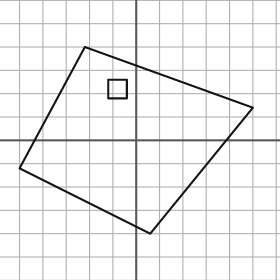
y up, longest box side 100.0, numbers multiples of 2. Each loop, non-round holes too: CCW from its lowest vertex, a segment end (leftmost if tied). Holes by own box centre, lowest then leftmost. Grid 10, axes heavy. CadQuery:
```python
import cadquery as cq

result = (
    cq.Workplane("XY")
    .moveTo(6.0, -40.0)
    .lineTo(50.0, 14.0)
    .lineTo(-22.0, 40.0)
    .lineTo(-50.0, -12.0)
    .close()
    .moveTo(-12.0, 18.0)
    .lineTo(-4.0, 18.0)
    .lineTo(-4.0, 26.0)
    .lineTo(-12.0, 26.0)
    .close()
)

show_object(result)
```